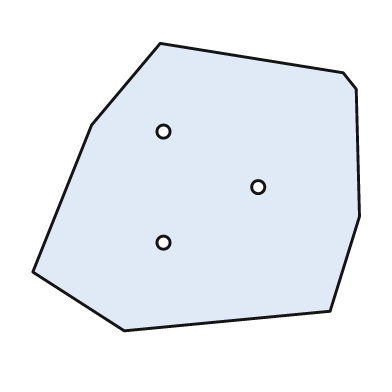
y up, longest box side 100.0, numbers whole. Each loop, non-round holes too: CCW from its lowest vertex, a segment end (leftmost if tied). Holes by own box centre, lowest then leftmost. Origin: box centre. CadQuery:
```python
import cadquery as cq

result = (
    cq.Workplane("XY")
    .moveTo(-22.0, -44.0)
    .lineTo(41.0, -38.0)
    .lineTo(50.0, -9.0)
    .lineTo(49.0, 30.0)
    .lineTo(45.0, 35.0)
    .lineTo(-11.0, 44.0)
    .lineTo(-32.0, 19.0)
    .lineTo(-50.0, -26.0)
    .close()
    .moveTo(-10.0, -17.0)
    .circle(2.0)
    .moveTo(19.0, 0.0)
    .circle(2.0)
    .moveTo(-10.0, 17.0)
    .circle(2.0)
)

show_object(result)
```